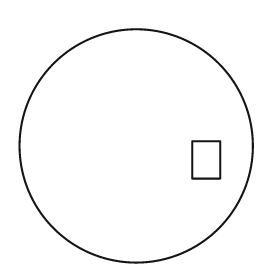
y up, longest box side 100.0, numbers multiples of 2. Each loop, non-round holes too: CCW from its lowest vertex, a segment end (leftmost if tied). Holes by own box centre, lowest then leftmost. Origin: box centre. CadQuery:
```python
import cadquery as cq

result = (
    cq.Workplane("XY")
    .moveTo(0.0, 0.0)
    .circle(50.0)
    .moveTo(24.0, -14.0)
    .lineTo(36.0, -14.0)
    .lineTo(36.0, 2.0)
    .lineTo(24.0, 2.0)
    .close()
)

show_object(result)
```